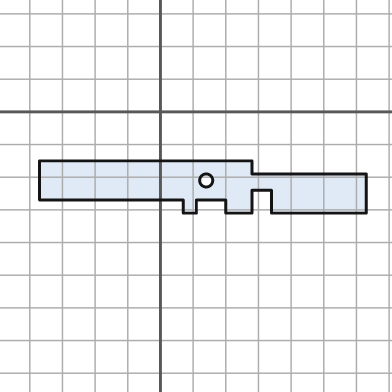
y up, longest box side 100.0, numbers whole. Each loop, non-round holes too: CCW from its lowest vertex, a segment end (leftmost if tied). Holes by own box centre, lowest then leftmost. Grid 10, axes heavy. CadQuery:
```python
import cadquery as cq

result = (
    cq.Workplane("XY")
    .moveTo(7.0, -31.0)
    .lineTo(11.0, -31.0)
    .lineTo(11.0, -27.0)
    .lineTo(20.0, -27.0)
    .lineTo(20.0, -31.0)
    .lineTo(28.0, -31.0)
    .lineTo(28.0, -24.0)
    .lineTo(34.0, -24.0)
    .lineTo(34.0, -31.0)
    .lineTo(63.0, -31.0)
    .lineTo(63.0, -19.0)
    .lineTo(28.0, -19.0)
    .lineTo(28.0, -15.0)
    .lineTo(-37.0, -15.0)
    .lineTo(-37.0, -27.0)
    .lineTo(7.0, -27.0)
    .close()
    .moveTo(14.0, -21.0)
    .circle(2.0)
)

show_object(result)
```